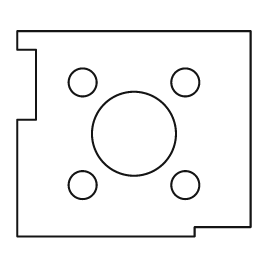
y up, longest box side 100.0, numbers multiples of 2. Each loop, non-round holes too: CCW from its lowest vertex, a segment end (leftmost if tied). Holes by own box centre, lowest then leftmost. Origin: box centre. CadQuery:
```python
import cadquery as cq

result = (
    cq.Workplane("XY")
    .moveTo(-50.0, -44.0)
    .lineTo(26.0, -44.0)
    .lineTo(26.0, -40.0)
    .lineTo(50.0, -40.0)
    .lineTo(50.0, 44.0)
    .lineTo(-50.0, 44.0)
    .lineTo(-50.0, 36.0)
    .lineTo(-42.0, 36.0)
    .lineTo(-42.0, 6.0)
    .lineTo(-50.0, 6.0)
    .close()
    .moveTo(-22.0, -22.0)
    .circle(6.0)
    .moveTo(22.0, -22.0)
    .circle(6.0)
    .moveTo(0.0, 0.0)
    .circle(18.0)
    .moveTo(-22.0, 22.0)
    .circle(6.0)
    .moveTo(22.0, 22.0)
    .circle(6.0)
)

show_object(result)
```